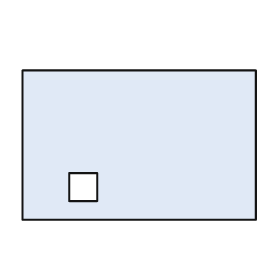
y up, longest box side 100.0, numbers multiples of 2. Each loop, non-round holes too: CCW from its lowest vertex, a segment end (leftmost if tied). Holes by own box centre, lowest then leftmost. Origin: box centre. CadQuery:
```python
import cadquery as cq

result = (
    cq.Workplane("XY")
    .moveTo(-50.0, -32.0)
    .lineTo(50.0, -32.0)
    .lineTo(50.0, 32.0)
    .lineTo(-50.0, 32.0)
    .close()
    .moveTo(-30.0, -24.0)
    .lineTo(-18.0, -24.0)
    .lineTo(-18.0, -12.0)
    .lineTo(-30.0, -12.0)
    .close()
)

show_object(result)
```